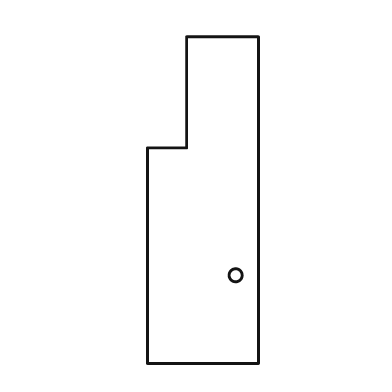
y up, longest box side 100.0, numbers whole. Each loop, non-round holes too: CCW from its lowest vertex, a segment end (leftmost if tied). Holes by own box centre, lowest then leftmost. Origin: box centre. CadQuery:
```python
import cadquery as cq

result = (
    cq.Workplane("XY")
    .moveTo(-17.0, -50.0)
    .lineTo(17.0, -50.0)
    .lineTo(17.0, 50.0)
    .lineTo(-5.0, 50.0)
    .lineTo(-5.0, 16.0)
    .lineTo(-17.0, 16.0)
    .close()
    .moveTo(10.0, -23.0)
    .circle(2.0)
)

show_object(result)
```